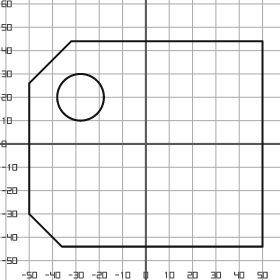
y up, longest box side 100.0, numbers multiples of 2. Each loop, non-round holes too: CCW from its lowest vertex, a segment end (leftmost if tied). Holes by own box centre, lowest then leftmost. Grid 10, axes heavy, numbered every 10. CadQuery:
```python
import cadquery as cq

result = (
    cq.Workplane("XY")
    .moveTo(-36.0, -44.0)
    .lineTo(50.0, -44.0)
    .lineTo(50.0, 44.0)
    .lineTo(-32.0, 44.0)
    .lineTo(-50.0, 26.0)
    .lineTo(-50.0, -30.0)
    .close()
    .moveTo(-28.0, 20.0)
    .circle(10.0)
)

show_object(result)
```